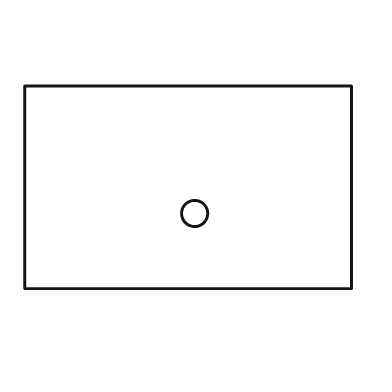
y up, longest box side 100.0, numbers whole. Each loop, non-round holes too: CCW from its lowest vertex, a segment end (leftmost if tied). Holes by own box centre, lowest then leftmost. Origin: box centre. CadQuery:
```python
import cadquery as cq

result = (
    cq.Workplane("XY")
    .moveTo(-50.0, -31.0)
    .lineTo(50.0, -31.0)
    .lineTo(50.0, 31.0)
    .lineTo(-50.0, 31.0)
    .close()
    .moveTo(2.0, -8.0)
    .circle(4.0)
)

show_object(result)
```